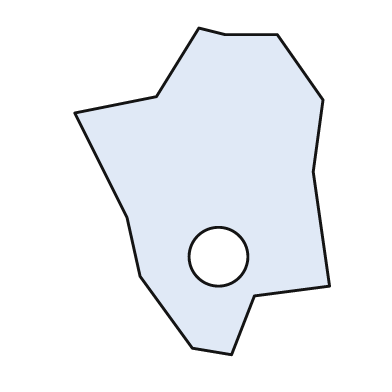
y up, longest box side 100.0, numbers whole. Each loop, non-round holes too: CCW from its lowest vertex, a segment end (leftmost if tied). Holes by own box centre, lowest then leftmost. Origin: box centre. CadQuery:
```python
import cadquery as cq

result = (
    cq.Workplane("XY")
    .moveTo(9.0, -50.0)
    .lineTo(16.0, -32.0)
    .lineTo(39.0, -29.0)
    .lineTo(34.0, 6.0)
    .lineTo(37.0, 28.0)
    .lineTo(23.0, 48.0)
    .lineTo(7.0, 48.0)
    .lineTo(-1.0, 50.0)
    .lineTo(-14.0, 29.0)
    .lineTo(-39.0, 24.0)
    .lineTo(-23.0, -8.0)
    .lineTo(-19.0, -26.0)
    .lineTo(-3.0, -48.0)
    .close()
    .moveTo(5.0, -20.0)
    .circle(9.0)
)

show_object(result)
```